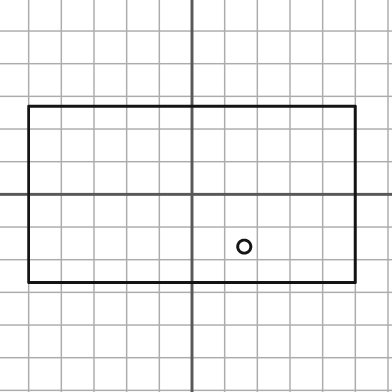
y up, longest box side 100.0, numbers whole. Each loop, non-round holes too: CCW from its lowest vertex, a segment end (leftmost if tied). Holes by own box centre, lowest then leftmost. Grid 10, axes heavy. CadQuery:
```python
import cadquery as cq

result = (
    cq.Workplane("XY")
    .moveTo(-50.0, -27.0)
    .lineTo(50.0, -27.0)
    .lineTo(50.0, 27.0)
    .lineTo(-50.0, 27.0)
    .close()
    .moveTo(16.0, -16.0)
    .circle(2.0)
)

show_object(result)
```